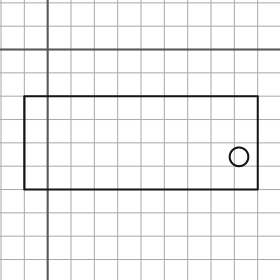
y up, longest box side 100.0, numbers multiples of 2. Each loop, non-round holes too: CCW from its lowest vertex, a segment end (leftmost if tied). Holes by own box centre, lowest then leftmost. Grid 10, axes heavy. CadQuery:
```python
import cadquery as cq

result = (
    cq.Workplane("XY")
    .moveTo(-10.0, -60.0)
    .lineTo(90.0, -60.0)
    .lineTo(90.0, -20.0)
    .lineTo(-10.0, -20.0)
    .close()
    .moveTo(82.0, -46.0)
    .circle(4.0)
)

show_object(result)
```